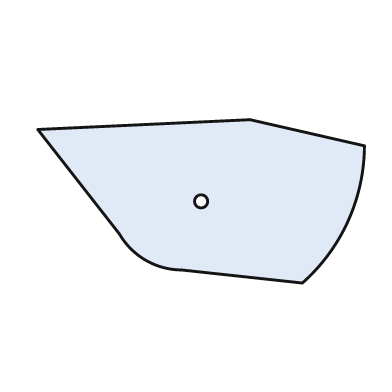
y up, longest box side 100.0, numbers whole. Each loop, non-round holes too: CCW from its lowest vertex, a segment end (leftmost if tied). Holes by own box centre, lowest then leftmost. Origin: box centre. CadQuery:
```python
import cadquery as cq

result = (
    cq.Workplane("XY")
    .moveTo(31.0, -25.0)
    .threePointArc((45.0, -6.0), (50.0, 17.0))
    .lineTo(15.0, 25.0)
    .lineTo(-50.0, 22.0)
    .lineTo(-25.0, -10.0)
    .threePointArc((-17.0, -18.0), (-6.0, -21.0))
    .close()
    .moveTo(0.0, 0.0)
    .circle(2.0)
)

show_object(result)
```